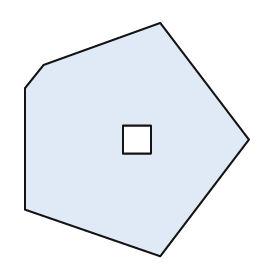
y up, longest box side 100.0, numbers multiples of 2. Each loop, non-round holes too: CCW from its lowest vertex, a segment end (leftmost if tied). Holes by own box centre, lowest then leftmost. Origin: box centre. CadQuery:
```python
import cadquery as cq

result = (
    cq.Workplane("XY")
    .moveTo(10.0, -50.0)
    .lineTo(48.0, 0.0)
    .lineTo(10.0, 50.0)
    .lineTo(-40.0, 32.0)
    .lineTo(-48.0, 22.0)
    .lineTo(-48.0, -30.0)
    .close()
    .moveTo(-6.0, -6.0)
    .lineTo(6.0, -6.0)
    .lineTo(6.0, 6.0)
    .lineTo(-6.0, 6.0)
    .close()
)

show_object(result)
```